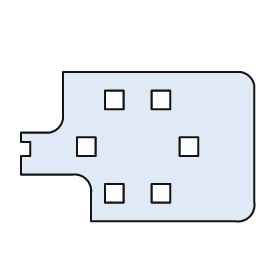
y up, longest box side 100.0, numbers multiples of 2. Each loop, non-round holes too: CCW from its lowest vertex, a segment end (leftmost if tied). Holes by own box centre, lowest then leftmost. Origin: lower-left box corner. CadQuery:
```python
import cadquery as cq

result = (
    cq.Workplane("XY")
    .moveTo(30.0, 0.0)
    .lineTo(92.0, 0.0)
    .threePointArc((98.0, 2.0), (100.0, 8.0))
    .lineTo(100.0, 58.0)
    .threePointArc((98.0, 62.0), (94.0, 64.0))
    .lineTo(18.0, 64.0)
    .lineTo(18.0, 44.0)
    .threePointArc((16.0, 40.0), (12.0, 38.0))
    .lineTo(0.0, 38.0)
    .lineTo(0.0, 34.0)
    .lineTo(4.0, 34.0)
    .lineTo(4.0, 28.0)
    .lineTo(0.0, 28.0)
    .lineTo(0.0, 20.0)
    .lineTo(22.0, 20.0)
    .threePointArc((28.0, 18.0), (30.0, 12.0))
    .close()
    .moveTo(36.0, 8.0)
    .lineTo(44.0, 8.0)
    .lineTo(44.0, 16.0)
    .lineTo(36.0, 16.0)
    .close()
    .moveTo(56.0, 8.0)
    .lineTo(64.0, 8.0)
    .lineTo(64.0, 16.0)
    .lineTo(56.0, 16.0)
    .close()
    .moveTo(24.0, 28.0)
    .lineTo(32.0, 28.0)
    .lineTo(32.0, 36.0)
    .lineTo(24.0, 36.0)
    .close()
    .moveTo(68.0, 28.0)
    .lineTo(76.0, 28.0)
    .lineTo(76.0, 36.0)
    .lineTo(68.0, 36.0)
    .close()
    .moveTo(36.0, 48.0)
    .lineTo(44.0, 48.0)
    .lineTo(44.0, 56.0)
    .lineTo(36.0, 56.0)
    .close()
    .moveTo(56.0, 48.0)
    .lineTo(64.0, 48.0)
    .lineTo(64.0, 56.0)
    .lineTo(56.0, 56.0)
    .close()
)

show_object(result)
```